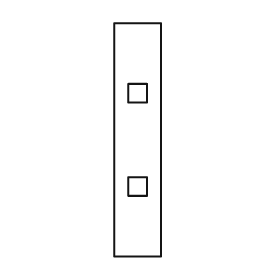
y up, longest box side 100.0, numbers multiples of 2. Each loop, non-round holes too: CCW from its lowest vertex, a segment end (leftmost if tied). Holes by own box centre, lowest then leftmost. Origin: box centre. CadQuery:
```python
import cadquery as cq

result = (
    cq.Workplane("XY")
    .moveTo(-10.0, -50.0)
    .lineTo(10.0, -50.0)
    .lineTo(10.0, 50.0)
    .lineTo(-10.0, 50.0)
    .close()
    .moveTo(-4.0, -24.0)
    .lineTo(4.0, -24.0)
    .lineTo(4.0, -16.0)
    .lineTo(-4.0, -16.0)
    .close()
    .moveTo(-4.0, 16.0)
    .lineTo(4.0, 16.0)
    .lineTo(4.0, 24.0)
    .lineTo(-4.0, 24.0)
    .close()
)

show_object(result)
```